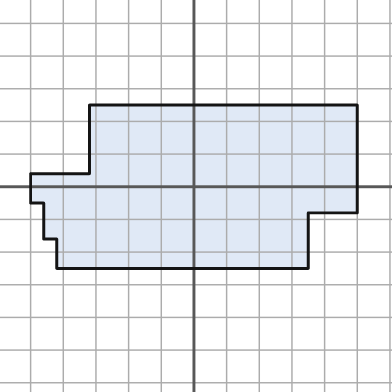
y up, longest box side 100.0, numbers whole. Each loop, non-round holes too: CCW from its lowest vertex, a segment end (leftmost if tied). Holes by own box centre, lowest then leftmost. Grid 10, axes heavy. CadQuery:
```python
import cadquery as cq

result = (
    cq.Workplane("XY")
    .moveTo(-42.0, -25.0)
    .lineTo(35.0, -25.0)
    .lineTo(35.0, -8.0)
    .lineTo(50.0, -8.0)
    .lineTo(50.0, 25.0)
    .lineTo(-32.0, 25.0)
    .lineTo(-32.0, 4.0)
    .lineTo(-50.0, 4.0)
    .lineTo(-50.0, -5.0)
    .lineTo(-46.0, -5.0)
    .lineTo(-46.0, -16.0)
    .lineTo(-42.0, -16.0)
    .close()
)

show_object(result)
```